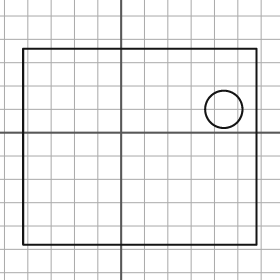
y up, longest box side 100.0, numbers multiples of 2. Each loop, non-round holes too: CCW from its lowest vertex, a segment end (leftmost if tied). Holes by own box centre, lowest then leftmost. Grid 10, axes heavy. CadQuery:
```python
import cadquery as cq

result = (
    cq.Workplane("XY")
    .moveTo(-42.0, -48.0)
    .lineTo(58.0, -48.0)
    .lineTo(58.0, 36.0)
    .lineTo(-42.0, 36.0)
    .close()
    .moveTo(44.0, 10.0)
    .circle(8.0)
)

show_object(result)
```